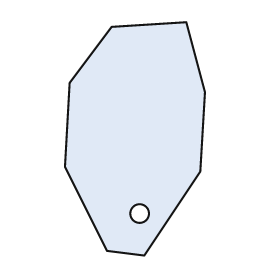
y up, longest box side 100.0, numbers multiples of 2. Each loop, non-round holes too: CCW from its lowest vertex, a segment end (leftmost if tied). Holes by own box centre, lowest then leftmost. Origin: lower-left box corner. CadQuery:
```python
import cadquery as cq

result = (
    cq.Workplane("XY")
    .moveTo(34.0, 0.0)
    .lineTo(58.0, 36.0)
    .lineTo(60.0, 70.0)
    .lineTo(52.0, 100.0)
    .lineTo(20.0, 98.0)
    .lineTo(2.0, 74.0)
    .lineTo(0.0, 38.0)
    .lineTo(18.0, 2.0)
    .close()
    .moveTo(32.0, 18.0)
    .circle(4.0)
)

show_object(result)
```